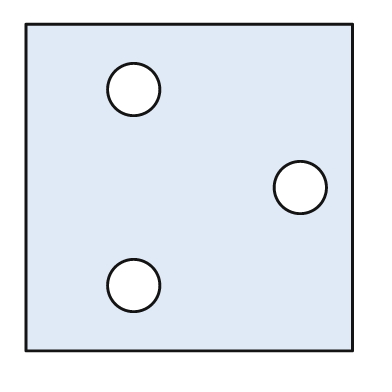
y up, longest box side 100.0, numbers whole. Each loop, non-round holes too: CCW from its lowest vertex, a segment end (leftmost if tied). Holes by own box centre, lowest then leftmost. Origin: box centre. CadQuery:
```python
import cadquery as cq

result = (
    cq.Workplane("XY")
    .moveTo(-50.0, -50.0)
    .lineTo(50.0, -50.0)
    .lineTo(50.0, 50.0)
    .lineTo(-50.0, 50.0)
    .close()
    .moveTo(-17.0, -30.0)
    .circle(8.0)
    .moveTo(34.0, 0.0)
    .circle(8.0)
    .moveTo(-17.0, 30.0)
    .circle(8.0)
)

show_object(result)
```